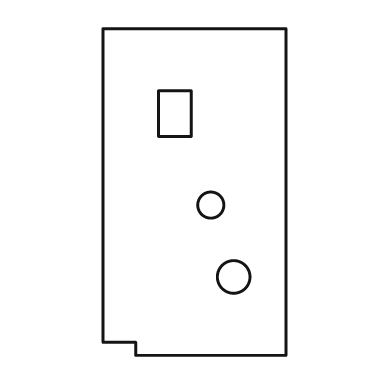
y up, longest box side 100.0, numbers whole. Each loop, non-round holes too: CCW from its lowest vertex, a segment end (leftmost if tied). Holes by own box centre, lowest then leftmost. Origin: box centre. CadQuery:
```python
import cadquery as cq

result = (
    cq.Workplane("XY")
    .moveTo(-18.0, -50.0)
    .lineTo(28.0, -50.0)
    .lineTo(28.0, 50.0)
    .lineTo(-28.0, 50.0)
    .lineTo(-28.0, -46.0)
    .lineTo(-18.0, -46.0)
    .close()
    .moveTo(12.0, -26.0)
    .circle(5.0)
    .moveTo(5.0, -4.0)
    .circle(4.0)
    .moveTo(-11.0, 17.0)
    .lineTo(-1.0, 17.0)
    .lineTo(-1.0, 31.0)
    .lineTo(-11.0, 31.0)
    .close()
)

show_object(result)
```